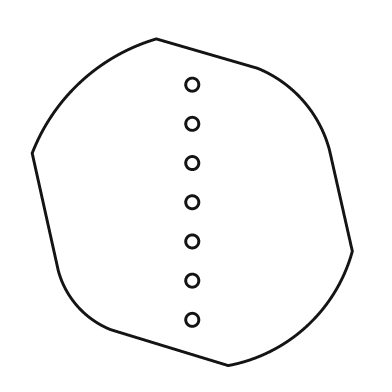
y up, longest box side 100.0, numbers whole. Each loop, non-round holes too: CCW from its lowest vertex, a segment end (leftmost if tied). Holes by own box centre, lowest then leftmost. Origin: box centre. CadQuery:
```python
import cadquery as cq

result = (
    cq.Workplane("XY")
    .moveTo(11.0, -50.0)
    .threePointArc((35.0, -38.0), (49.0, -15.0))
    .lineTo(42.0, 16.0)
    .threePointArc((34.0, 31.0), (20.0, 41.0))
    .lineTo(-11.0, 50.0)
    .threePointArc((-34.0, 37.0), (-49.0, 15.0))
    .lineTo(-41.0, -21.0)
    .threePointArc((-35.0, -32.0), (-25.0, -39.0))
    .close()
    .moveTo(0.0, -36.0)
    .circle(2.0)
    .moveTo(0.0, -24.0)
    .circle(2.0)
    .moveTo(0.0, -12.0)
    .circle(2.0)
    .moveTo(0.0, 0.0)
    .circle(2.0)
    .moveTo(0.0, 12.0)
    .circle(2.0)
    .moveTo(0.0, 24.0)
    .circle(2.0)
    .moveTo(0.0, 36.0)
    .circle(2.0)
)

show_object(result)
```